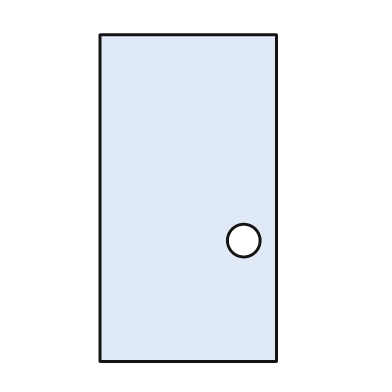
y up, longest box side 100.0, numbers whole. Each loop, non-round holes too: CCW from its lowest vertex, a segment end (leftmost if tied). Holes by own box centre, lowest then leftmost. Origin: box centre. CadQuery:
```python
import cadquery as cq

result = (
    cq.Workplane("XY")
    .moveTo(-27.0, -50.0)
    .lineTo(27.0, -50.0)
    .lineTo(27.0, 50.0)
    .lineTo(-27.0, 50.0)
    .close()
    .moveTo(17.0, -13.0)
    .circle(5.0)
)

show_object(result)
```